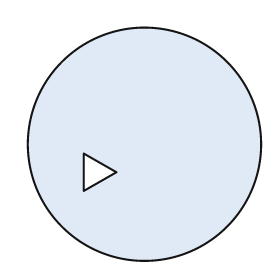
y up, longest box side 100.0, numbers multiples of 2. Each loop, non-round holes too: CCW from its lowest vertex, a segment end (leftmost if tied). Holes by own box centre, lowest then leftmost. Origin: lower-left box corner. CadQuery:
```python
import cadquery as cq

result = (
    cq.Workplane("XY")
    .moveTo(50.0, 50.0)
    .circle(50.0)
    .moveTo(24.0, 30.0)
    .lineTo(38.0, 38.0)
    .lineTo(24.0, 46.0)
    .close()
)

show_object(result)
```